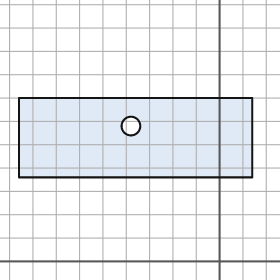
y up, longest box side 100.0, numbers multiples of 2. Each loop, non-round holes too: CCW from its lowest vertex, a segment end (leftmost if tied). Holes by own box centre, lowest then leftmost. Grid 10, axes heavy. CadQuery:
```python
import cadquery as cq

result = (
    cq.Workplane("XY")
    .moveTo(-86.0, 36.0)
    .lineTo(14.0, 36.0)
    .lineTo(14.0, 70.0)
    .lineTo(-86.0, 70.0)
    .close()
    .moveTo(-38.0, 58.0)
    .circle(4.0)
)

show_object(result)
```